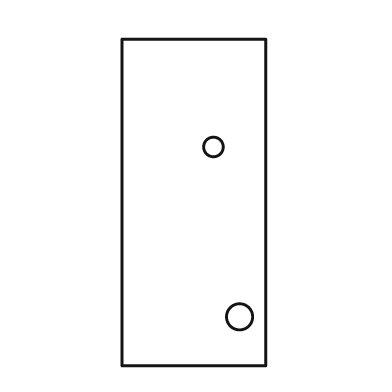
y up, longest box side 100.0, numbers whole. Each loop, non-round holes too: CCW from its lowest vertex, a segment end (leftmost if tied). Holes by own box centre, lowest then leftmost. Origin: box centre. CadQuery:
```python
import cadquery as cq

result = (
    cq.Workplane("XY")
    .moveTo(-22.0, -50.0)
    .lineTo(22.0, -50.0)
    .lineTo(22.0, 50.0)
    .lineTo(-22.0, 50.0)
    .close()
    .moveTo(14.0, -35.0)
    .circle(4.0)
    .moveTo(6.0, 17.0)
    .circle(3.0)
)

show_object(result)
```